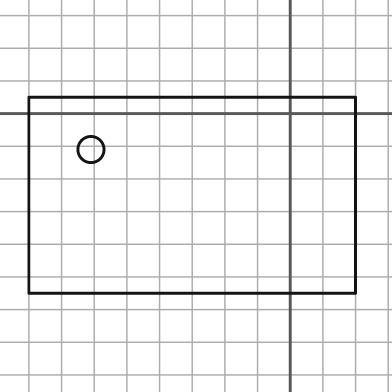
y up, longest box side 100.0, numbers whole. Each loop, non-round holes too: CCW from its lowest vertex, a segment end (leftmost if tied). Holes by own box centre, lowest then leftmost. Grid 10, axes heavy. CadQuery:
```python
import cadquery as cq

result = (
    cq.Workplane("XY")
    .moveTo(-80.0, -55.0)
    .lineTo(20.0, -55.0)
    .lineTo(20.0, 5.0)
    .lineTo(-80.0, 5.0)
    .close()
    .moveTo(-61.0, -11.0)
    .circle(4.0)
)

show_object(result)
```